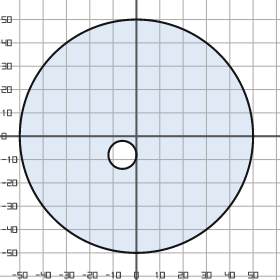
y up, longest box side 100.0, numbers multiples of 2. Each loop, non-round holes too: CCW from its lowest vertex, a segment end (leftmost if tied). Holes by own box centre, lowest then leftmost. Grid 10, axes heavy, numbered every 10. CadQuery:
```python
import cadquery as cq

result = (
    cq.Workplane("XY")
    .moveTo(0.0, 0.0)
    .circle(50.0)
    .moveTo(-6.0, -8.0)
    .circle(6.0)
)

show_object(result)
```